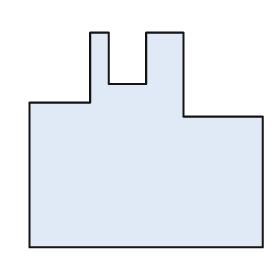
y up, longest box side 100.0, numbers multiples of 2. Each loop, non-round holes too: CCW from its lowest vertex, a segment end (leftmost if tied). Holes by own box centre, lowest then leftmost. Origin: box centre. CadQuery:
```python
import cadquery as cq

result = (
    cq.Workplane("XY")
    .moveTo(-50.0, -46.0)
    .lineTo(50.0, -46.0)
    .lineTo(50.0, 10.0)
    .lineTo(16.0, 10.0)
    .lineTo(16.0, 46.0)
    .lineTo(0.0, 46.0)
    .lineTo(0.0, 24.0)
    .lineTo(-16.0, 24.0)
    .lineTo(-16.0, 46.0)
    .lineTo(-24.0, 46.0)
    .lineTo(-24.0, 16.0)
    .lineTo(-50.0, 16.0)
    .close()
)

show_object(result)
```